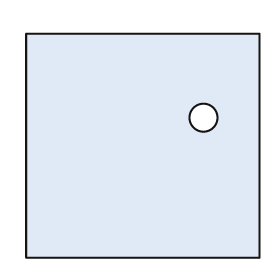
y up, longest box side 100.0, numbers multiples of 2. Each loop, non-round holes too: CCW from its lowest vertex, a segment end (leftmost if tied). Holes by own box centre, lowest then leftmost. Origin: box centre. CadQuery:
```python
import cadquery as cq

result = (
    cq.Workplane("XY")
    .moveTo(-50.0, -48.0)
    .lineTo(50.0, -48.0)
    .lineTo(50.0, 48.0)
    .lineTo(-50.0, 48.0)
    .close()
    .moveTo(26.0, 12.0)
    .circle(6.0)
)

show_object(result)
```